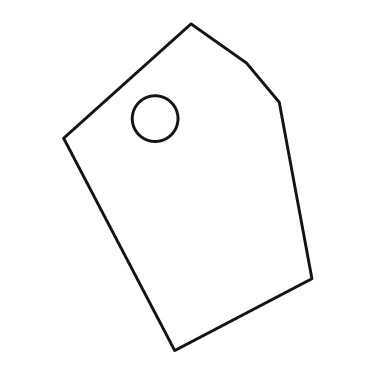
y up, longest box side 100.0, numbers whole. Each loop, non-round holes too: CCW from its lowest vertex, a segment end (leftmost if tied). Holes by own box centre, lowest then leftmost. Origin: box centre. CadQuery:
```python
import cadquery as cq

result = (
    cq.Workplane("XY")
    .moveTo(-4.0, -50.0)
    .lineTo(38.0, -28.0)
    .lineTo(28.0, 26.0)
    .lineTo(18.0, 38.0)
    .lineTo(1.0, 50.0)
    .lineTo(-38.0, 15.0)
    .close()
    .moveTo(-10.0, 21.0)
    .circle(7.0)
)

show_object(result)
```